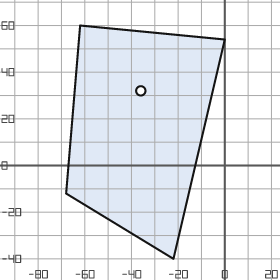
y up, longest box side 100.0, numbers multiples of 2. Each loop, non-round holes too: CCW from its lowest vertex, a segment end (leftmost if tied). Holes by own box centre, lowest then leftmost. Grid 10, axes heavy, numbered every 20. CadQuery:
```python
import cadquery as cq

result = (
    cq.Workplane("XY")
    .moveTo(-22.0, -40.0)
    .lineTo(0.0, 54.0)
    .lineTo(-62.0, 60.0)
    .lineTo(-68.0, -12.0)
    .close()
    .moveTo(-36.0, 32.0)
    .circle(2.0)
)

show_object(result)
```